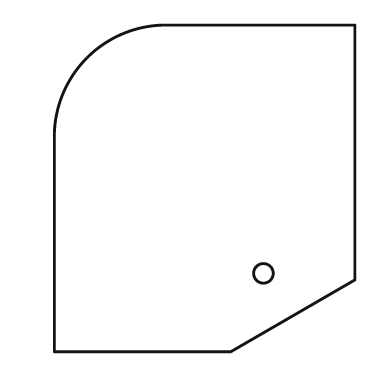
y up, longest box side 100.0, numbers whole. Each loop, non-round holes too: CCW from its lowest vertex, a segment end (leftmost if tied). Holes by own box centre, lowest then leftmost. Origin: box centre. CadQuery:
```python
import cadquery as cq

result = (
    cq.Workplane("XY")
    .moveTo(-46.0, -50.0)
    .lineTo(8.0, -50.0)
    .lineTo(46.0, -28.0)
    .lineTo(46.0, 50.0)
    .lineTo(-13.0, 50.0)
    .threePointArc((-36.0, 40.0), (-46.0, 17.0))
    .close()
    .moveTo(18.0, -26.0)
    .circle(3.0)
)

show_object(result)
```